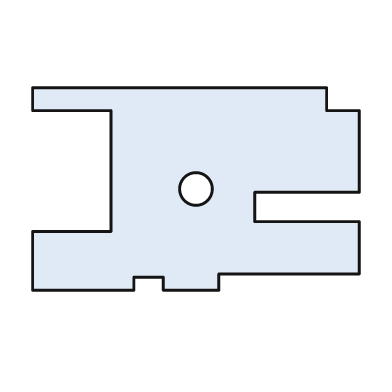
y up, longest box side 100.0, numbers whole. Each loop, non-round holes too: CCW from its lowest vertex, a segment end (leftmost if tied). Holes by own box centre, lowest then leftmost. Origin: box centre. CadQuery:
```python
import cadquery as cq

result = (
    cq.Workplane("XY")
    .moveTo(-50.0, -31.0)
    .lineTo(-19.0, -31.0)
    .lineTo(-19.0, -27.0)
    .lineTo(-10.0, -27.0)
    .lineTo(-10.0, -31.0)
    .lineTo(7.0, -31.0)
    .lineTo(7.0, -26.0)
    .lineTo(50.0, -26.0)
    .lineTo(50.0, -10.0)
    .lineTo(18.0, -10.0)
    .lineTo(18.0, -1.0)
    .lineTo(50.0, -1.0)
    .lineTo(50.0, 24.0)
    .lineTo(40.0, 24.0)
    .lineTo(40.0, 31.0)
    .lineTo(-50.0, 31.0)
    .lineTo(-50.0, 24.0)
    .lineTo(-26.0, 24.0)
    .lineTo(-26.0, -13.0)
    .lineTo(-50.0, -13.0)
    .close()
    .moveTo(0.0, 0.0)
    .circle(5.0)
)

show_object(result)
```